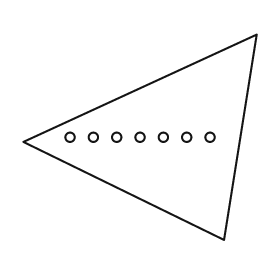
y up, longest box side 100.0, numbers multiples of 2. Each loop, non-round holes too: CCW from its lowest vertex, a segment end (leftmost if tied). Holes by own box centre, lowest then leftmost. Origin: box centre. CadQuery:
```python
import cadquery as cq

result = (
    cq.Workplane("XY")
    .moveTo(36.0, -44.0)
    .lineTo(50.0, 44.0)
    .lineTo(-50.0, -2.0)
    .close()
    .moveTo(-30.0, 0.0)
    .circle(2.0)
    .moveTo(-20.0, 0.0)
    .circle(2.0)
    .moveTo(-10.0, 0.0)
    .circle(2.0)
    .moveTo(0.0, 0.0)
    .circle(2.0)
    .moveTo(10.0, 0.0)
    .circle(2.0)
    .moveTo(20.0, 0.0)
    .circle(2.0)
    .moveTo(30.0, 0.0)
    .circle(2.0)
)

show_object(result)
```